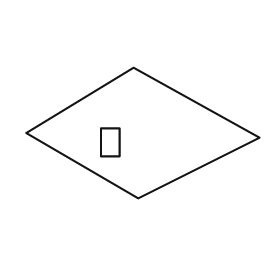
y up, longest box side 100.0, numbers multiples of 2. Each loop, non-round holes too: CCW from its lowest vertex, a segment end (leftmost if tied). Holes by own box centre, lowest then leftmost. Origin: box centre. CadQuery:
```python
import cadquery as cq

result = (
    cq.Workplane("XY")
    .moveTo(-2.0, -28.0)
    .lineTo(50.0, -2.0)
    .lineTo(-4.0, 28.0)
    .lineTo(-50.0, 0.0)
    .close()
    .moveTo(-18.0, -10.0)
    .lineTo(-10.0, -10.0)
    .lineTo(-10.0, 2.0)
    .lineTo(-18.0, 2.0)
    .close()
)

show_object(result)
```